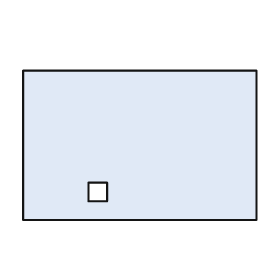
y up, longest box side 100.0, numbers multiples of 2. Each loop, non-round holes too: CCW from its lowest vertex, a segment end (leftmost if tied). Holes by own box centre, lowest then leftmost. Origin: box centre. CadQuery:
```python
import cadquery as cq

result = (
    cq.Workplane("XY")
    .moveTo(-50.0, -32.0)
    .lineTo(50.0, -32.0)
    .lineTo(50.0, 32.0)
    .lineTo(-50.0, 32.0)
    .close()
    .moveTo(-22.0, -24.0)
    .lineTo(-14.0, -24.0)
    .lineTo(-14.0, -16.0)
    .lineTo(-22.0, -16.0)
    .close()
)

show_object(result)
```